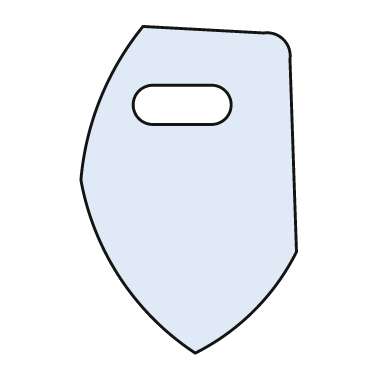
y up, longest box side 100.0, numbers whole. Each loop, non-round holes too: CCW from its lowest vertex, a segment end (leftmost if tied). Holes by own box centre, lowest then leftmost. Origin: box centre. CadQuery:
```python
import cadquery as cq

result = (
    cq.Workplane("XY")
    .moveTo(2.0, -50.0)
    .threePointArc((20.0, -37.0), (33.0, -19.0))
    .lineTo(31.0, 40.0)
    .threePointArc((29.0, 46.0), (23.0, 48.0))
    .lineTo(-14.0, 50.0)
    .threePointArc((-27.0, 28.0), (-33.0, 3.0))
    .threePointArc((-21.0, -27.0), (2.0, -50.0))
    .close()
    .moveTo(-11.0, 20.0)
    .lineTo(7.0, 20.0)
    .threePointArc((13.0, 26.0), (7.0, 32.0))
    .lineTo(-11.0, 32.0)
    .threePointArc((-17.0, 26.0), (-11.0, 20.0))
    .close()
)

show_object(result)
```